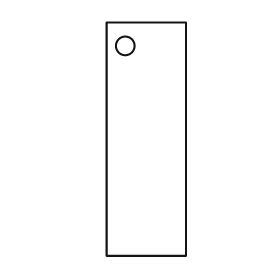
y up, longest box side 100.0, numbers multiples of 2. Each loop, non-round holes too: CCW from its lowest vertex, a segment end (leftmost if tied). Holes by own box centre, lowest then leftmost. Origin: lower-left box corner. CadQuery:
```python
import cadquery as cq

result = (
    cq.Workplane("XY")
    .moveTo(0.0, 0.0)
    .lineTo(34.0, 0.0)
    .lineTo(34.0, 100.0)
    .lineTo(0.0, 100.0)
    .close()
    .moveTo(8.0, 90.0)
    .circle(4.0)
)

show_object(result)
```